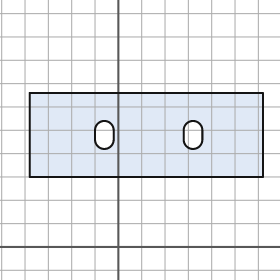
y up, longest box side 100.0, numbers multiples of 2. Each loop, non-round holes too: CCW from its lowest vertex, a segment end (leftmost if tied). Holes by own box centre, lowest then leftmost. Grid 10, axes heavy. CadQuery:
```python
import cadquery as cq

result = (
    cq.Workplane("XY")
    .moveTo(-38.0, 30.0)
    .lineTo(62.0, 30.0)
    .lineTo(62.0, 66.0)
    .lineTo(-38.0, 66.0)
    .close()
    .moveTo(-10.0, 46.0)
    .threePointArc((-6.0, 42.0), (-2.0, 46.0))
    .lineTo(-2.0, 50.0)
    .threePointArc((-6.0, 54.0), (-10.0, 50.0))
    .close()
    .moveTo(28.0, 46.0)
    .threePointArc((32.0, 42.0), (36.0, 46.0))
    .lineTo(36.0, 50.0)
    .threePointArc((32.0, 54.0), (28.0, 50.0))
    .close()
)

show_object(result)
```